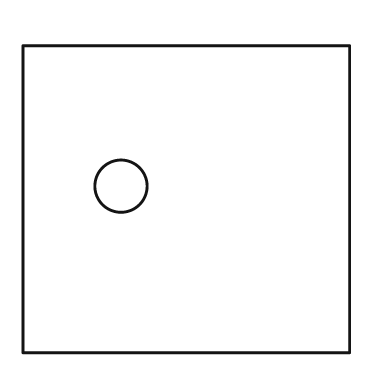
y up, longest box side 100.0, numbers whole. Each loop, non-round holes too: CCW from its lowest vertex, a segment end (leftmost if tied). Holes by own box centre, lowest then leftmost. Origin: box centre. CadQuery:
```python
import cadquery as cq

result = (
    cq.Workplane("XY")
    .moveTo(-50.0, -47.0)
    .lineTo(50.0, -47.0)
    .lineTo(50.0, 47.0)
    .lineTo(-50.0, 47.0)
    .close()
    .moveTo(-20.0, 4.0)
    .circle(8.0)
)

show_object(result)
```